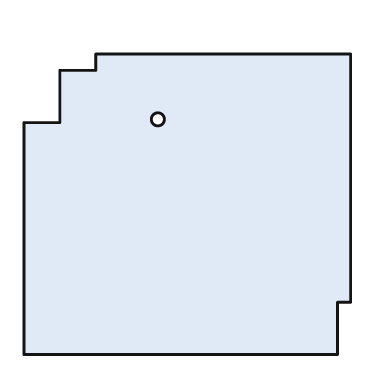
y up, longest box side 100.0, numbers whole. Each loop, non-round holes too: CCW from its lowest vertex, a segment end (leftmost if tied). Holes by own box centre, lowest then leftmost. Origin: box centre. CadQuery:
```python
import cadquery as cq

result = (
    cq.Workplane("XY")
    .moveTo(-50.0, -46.0)
    .lineTo(46.0, -46.0)
    .lineTo(46.0, -30.0)
    .lineTo(50.0, -30.0)
    .lineTo(50.0, 46.0)
    .lineTo(-28.0, 46.0)
    .lineTo(-28.0, 41.0)
    .lineTo(-39.0, 41.0)
    .lineTo(-39.0, 25.0)
    .lineTo(-50.0, 25.0)
    .close()
    .moveTo(-9.0, 26.0)
    .circle(2.0)
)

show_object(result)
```